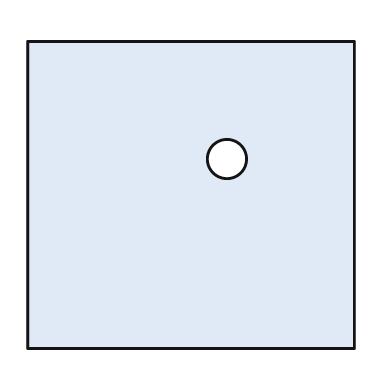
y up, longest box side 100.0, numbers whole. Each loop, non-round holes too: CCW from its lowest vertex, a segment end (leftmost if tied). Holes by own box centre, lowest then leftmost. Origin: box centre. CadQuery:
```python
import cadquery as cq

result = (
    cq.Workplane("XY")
    .moveTo(-50.0, -47.0)
    .lineTo(50.0, -47.0)
    .lineTo(50.0, 47.0)
    .lineTo(-50.0, 47.0)
    .close()
    .moveTo(11.0, 11.0)
    .circle(6.0)
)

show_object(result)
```